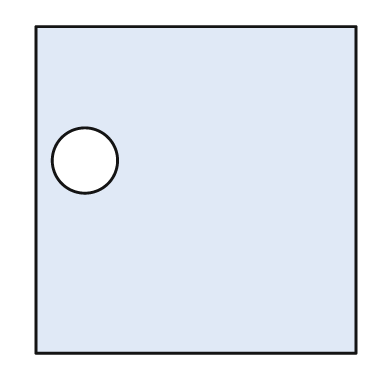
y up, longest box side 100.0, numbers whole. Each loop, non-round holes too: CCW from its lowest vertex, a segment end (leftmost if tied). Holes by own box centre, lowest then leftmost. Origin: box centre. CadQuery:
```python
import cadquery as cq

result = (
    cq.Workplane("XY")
    .moveTo(-49.0, -50.0)
    .lineTo(49.0, -50.0)
    .lineTo(49.0, 50.0)
    .lineTo(-49.0, 50.0)
    .close()
    .moveTo(-34.0, 9.0)
    .circle(10.0)
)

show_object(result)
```